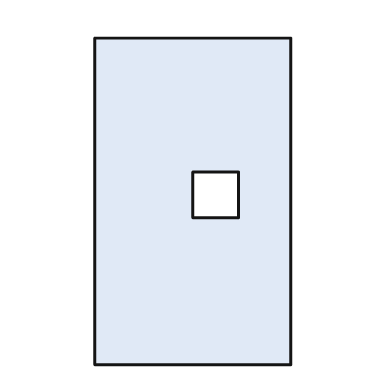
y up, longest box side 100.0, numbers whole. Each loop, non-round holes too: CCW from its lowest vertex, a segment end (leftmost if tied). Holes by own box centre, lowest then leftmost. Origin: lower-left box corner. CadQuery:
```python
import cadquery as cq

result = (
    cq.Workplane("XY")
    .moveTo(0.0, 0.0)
    .lineTo(60.0, 0.0)
    .lineTo(60.0, 100.0)
    .lineTo(0.0, 100.0)
    .close()
    .moveTo(30.0, 45.0)
    .lineTo(44.0, 45.0)
    .lineTo(44.0, 59.0)
    .lineTo(30.0, 59.0)
    .close()
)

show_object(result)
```